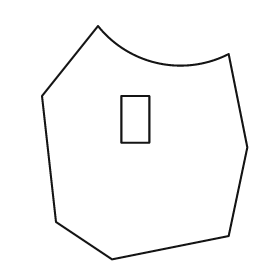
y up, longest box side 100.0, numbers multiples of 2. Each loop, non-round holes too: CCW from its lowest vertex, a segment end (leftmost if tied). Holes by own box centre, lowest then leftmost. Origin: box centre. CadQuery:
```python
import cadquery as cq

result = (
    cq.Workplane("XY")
    .moveTo(-14.0, -50.0)
    .lineTo(36.0, -40.0)
    .lineTo(44.0, -2.0)
    .lineTo(36.0, 38.0)
    .threePointArc((6.0, 34.0), (-20.0, 50.0))
    .lineTo(-44.0, 20.0)
    .lineTo(-38.0, -34.0)
    .close()
    .moveTo(-10.0, 0.0)
    .lineTo(2.0, 0.0)
    .lineTo(2.0, 20.0)
    .lineTo(-10.0, 20.0)
    .close()
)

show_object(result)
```